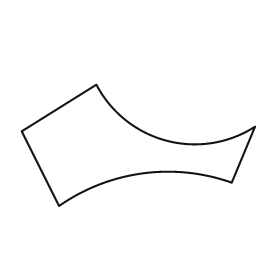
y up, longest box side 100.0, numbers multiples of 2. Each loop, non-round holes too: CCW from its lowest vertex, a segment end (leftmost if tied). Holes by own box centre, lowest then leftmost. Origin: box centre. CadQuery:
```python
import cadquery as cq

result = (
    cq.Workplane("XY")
    .moveTo(-34.0, -26.0)
    .threePointArc((2.0, -12.0), (40.0, -16.0))
    .lineTo(50.0, 8.0)
    .threePointArc((12.0, 2.0), (-18.0, 26.0))
    .lineTo(-50.0, 6.0)
    .close()
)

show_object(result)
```